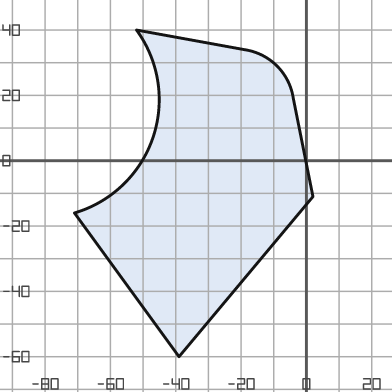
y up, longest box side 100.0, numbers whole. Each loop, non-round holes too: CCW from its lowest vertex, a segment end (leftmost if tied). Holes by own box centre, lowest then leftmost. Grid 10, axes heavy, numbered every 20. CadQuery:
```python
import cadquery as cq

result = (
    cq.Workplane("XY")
    .moveTo(-39.0, -60.0)
    .lineTo(2.0, -11.0)
    .lineTo(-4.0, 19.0)
    .threePointArc((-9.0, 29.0), (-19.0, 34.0))
    .lineTo(-52.0, 40.0)
    .threePointArc((-47.0, 7.0), (-71.0, -16.0))
    .close()
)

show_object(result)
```